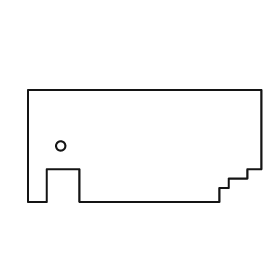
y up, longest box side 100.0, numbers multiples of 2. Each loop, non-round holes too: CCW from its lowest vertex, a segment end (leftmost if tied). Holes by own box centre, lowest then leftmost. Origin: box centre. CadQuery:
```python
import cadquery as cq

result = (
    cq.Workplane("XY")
    .moveTo(-50.0, -24.0)
    .lineTo(-42.0, -24.0)
    .lineTo(-42.0, -10.0)
    .lineTo(-28.0, -10.0)
    .lineTo(-28.0, -24.0)
    .lineTo(32.0, -24.0)
    .lineTo(32.0, -18.0)
    .lineTo(36.0, -18.0)
    .lineTo(36.0, -14.0)
    .lineTo(44.0, -14.0)
    .lineTo(44.0, -10.0)
    .lineTo(50.0, -10.0)
    .lineTo(50.0, 24.0)
    .lineTo(-50.0, 24.0)
    .close()
    .moveTo(-36.0, 0.0)
    .circle(2.0)
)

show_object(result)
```